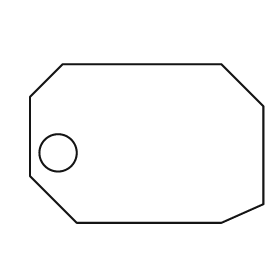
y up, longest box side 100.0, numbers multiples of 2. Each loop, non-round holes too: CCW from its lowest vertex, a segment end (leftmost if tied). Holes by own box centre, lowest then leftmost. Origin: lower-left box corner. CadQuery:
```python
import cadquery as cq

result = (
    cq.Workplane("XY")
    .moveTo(20.0, 0.0)
    .lineTo(82.0, 0.0)
    .lineTo(100.0, 8.0)
    .lineTo(100.0, 50.0)
    .lineTo(82.0, 68.0)
    .lineTo(14.0, 68.0)
    .lineTo(0.0, 54.0)
    .lineTo(0.0, 20.0)
    .close()
    .moveTo(12.0, 30.0)
    .circle(8.0)
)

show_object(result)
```